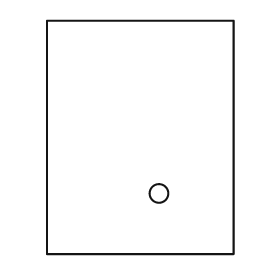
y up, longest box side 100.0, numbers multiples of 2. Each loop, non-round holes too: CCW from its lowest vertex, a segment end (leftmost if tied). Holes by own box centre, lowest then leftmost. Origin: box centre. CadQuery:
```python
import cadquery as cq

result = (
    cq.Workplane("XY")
    .moveTo(-40.0, -50.0)
    .lineTo(40.0, -50.0)
    .lineTo(40.0, 50.0)
    .lineTo(-40.0, 50.0)
    .close()
    .moveTo(8.0, -24.0)
    .circle(4.0)
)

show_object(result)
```